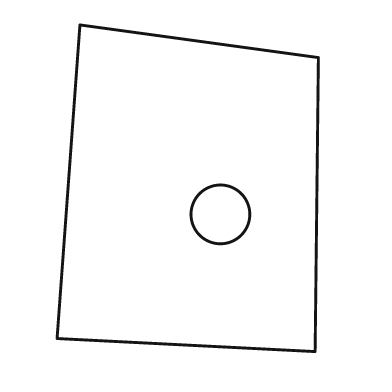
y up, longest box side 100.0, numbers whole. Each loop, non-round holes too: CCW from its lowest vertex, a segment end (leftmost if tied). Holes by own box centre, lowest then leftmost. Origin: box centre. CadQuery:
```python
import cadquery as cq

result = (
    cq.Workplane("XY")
    .moveTo(39.0, -50.0)
    .lineTo(40.0, 40.0)
    .lineTo(-33.0, 50.0)
    .lineTo(-40.0, -46.0)
    .close()
    .moveTo(10.0, -8.0)
    .circle(9.0)
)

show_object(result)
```